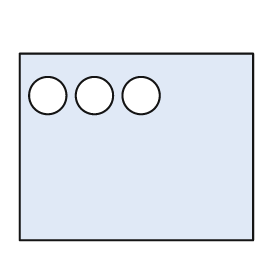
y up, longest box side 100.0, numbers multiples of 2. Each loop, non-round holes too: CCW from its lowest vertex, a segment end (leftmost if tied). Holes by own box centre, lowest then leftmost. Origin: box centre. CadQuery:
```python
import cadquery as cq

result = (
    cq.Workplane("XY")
    .moveTo(-50.0, -40.0)
    .lineTo(50.0, -40.0)
    .lineTo(50.0, 40.0)
    .lineTo(-50.0, 40.0)
    .close()
    .moveTo(-38.0, 22.0)
    .circle(8.0)
    .moveTo(-18.0, 22.0)
    .circle(8.0)
    .moveTo(2.0, 22.0)
    .circle(8.0)
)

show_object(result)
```